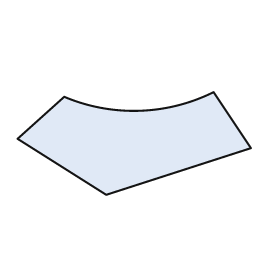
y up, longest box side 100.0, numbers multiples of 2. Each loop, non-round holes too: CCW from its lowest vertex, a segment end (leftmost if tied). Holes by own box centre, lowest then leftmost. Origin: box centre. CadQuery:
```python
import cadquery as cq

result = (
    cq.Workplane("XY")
    .moveTo(-12.0, -22.0)
    .lineTo(50.0, -2.0)
    .lineTo(34.0, 22.0)
    .threePointArc((2.0, 14.0), (-30.0, 20.0))
    .lineTo(-50.0, 2.0)
    .close()
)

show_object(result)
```